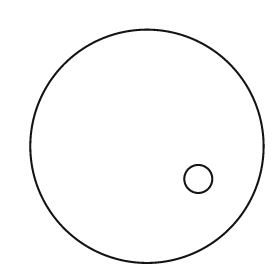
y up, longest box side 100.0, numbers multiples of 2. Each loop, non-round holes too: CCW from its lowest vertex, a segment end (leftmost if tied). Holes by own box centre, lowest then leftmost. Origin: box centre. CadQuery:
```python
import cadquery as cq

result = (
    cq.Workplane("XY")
    .moveTo(0.0, 0.0)
    .circle(50.0)
    .moveTo(22.0, -14.0)
    .circle(6.0)
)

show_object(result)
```